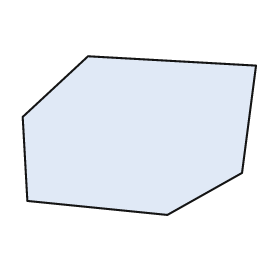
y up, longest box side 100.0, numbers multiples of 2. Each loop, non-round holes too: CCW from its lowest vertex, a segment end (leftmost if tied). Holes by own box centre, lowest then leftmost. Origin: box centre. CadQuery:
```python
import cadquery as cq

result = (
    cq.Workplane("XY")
    .moveTo(12.0, -34.0)
    .lineTo(44.0, -16.0)
    .lineTo(50.0, 30.0)
    .lineTo(-22.0, 34.0)
    .lineTo(-50.0, 8.0)
    .lineTo(-48.0, -28.0)
    .close()
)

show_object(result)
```